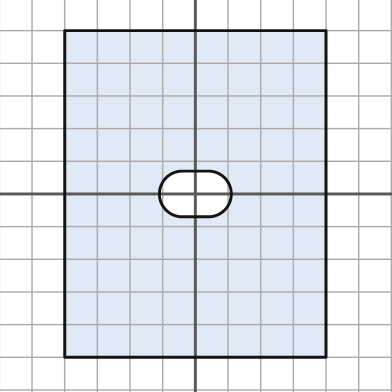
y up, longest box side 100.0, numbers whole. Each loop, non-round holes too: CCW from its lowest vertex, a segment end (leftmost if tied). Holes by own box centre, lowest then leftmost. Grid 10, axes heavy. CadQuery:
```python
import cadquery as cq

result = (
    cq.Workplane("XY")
    .moveTo(-40.0, -50.0)
    .lineTo(40.0, -50.0)
    .lineTo(40.0, 50.0)
    .lineTo(-40.0, 50.0)
    .close()
    .moveTo(-4.0, -7.0)
    .lineTo(4.0, -7.0)
    .threePointArc((11.0, 0.0), (4.0, 7.0))
    .lineTo(-4.0, 7.0)
    .threePointArc((-11.0, 0.0), (-4.0, -7.0))
    .close()
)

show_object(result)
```